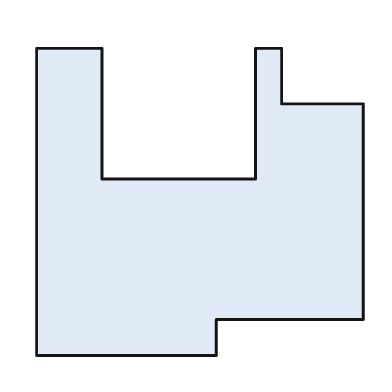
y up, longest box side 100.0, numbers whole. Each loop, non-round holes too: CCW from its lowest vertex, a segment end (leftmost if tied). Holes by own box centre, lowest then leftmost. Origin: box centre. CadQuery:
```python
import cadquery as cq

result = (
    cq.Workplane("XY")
    .moveTo(-50.0, -47.0)
    .lineTo(5.0, -47.0)
    .lineTo(5.0, -36.0)
    .lineTo(50.0, -36.0)
    .lineTo(50.0, 30.0)
    .lineTo(25.0, 30.0)
    .lineTo(25.0, 47.0)
    .lineTo(17.0, 47.0)
    .lineTo(17.0, 7.0)
    .lineTo(-30.0, 7.0)
    .lineTo(-30.0, 47.0)
    .lineTo(-50.0, 47.0)
    .close()
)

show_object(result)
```